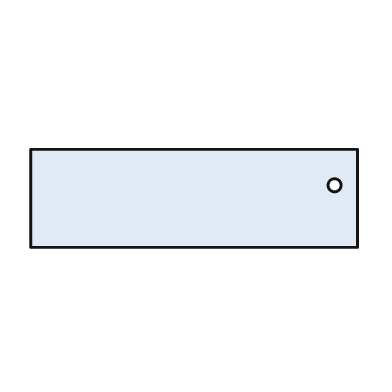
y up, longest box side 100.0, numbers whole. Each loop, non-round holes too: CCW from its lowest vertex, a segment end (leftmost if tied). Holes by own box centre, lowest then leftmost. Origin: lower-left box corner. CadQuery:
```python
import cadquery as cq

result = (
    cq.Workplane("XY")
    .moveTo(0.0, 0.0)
    .lineTo(100.0, 0.0)
    .lineTo(100.0, 30.0)
    .lineTo(0.0, 30.0)
    .close()
    .moveTo(93.0, 19.0)
    .circle(2.0)
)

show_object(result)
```